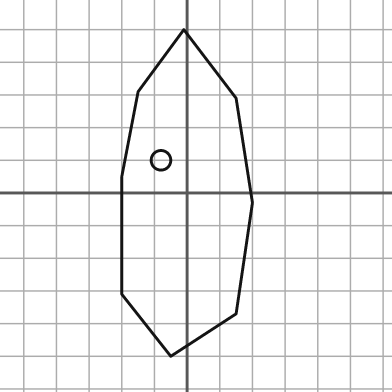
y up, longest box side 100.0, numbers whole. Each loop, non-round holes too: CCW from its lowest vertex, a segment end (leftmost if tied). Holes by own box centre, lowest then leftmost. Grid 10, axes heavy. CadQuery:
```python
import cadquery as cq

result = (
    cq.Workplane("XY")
    .moveTo(-5.0, -50.0)
    .lineTo(15.0, -37.0)
    .lineTo(20.0, -3.0)
    .lineTo(15.0, 29.0)
    .lineTo(-1.0, 50.0)
    .lineTo(-15.0, 31.0)
    .lineTo(-20.0, 5.0)
    .lineTo(-20.0, -31.0)
    .close()
    .moveTo(-8.0, 10.0)
    .circle(3.0)
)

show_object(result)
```